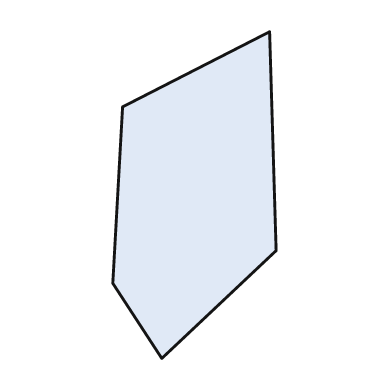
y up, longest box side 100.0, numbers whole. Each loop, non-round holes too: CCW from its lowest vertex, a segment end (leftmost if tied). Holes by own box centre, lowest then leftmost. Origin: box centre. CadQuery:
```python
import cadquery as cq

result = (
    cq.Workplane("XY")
    .moveTo(-10.0, -50.0)
    .lineTo(25.0, -17.0)
    .lineTo(23.0, 50.0)
    .lineTo(-22.0, 27.0)
    .lineTo(-25.0, -27.0)
    .close()
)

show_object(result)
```